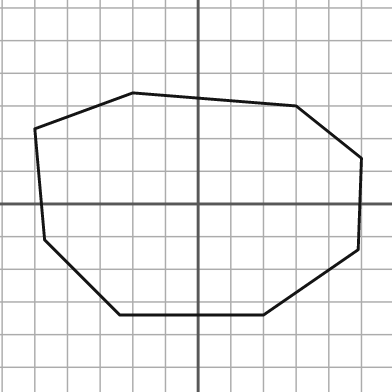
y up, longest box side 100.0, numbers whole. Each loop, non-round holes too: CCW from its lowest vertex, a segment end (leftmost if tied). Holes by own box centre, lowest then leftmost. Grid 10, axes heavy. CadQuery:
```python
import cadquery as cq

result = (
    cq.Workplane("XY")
    .moveTo(-24.0, -34.0)
    .lineTo(20.0, -34.0)
    .lineTo(49.0, -14.0)
    .lineTo(50.0, 14.0)
    .lineTo(30.0, 30.0)
    .lineTo(-20.0, 34.0)
    .lineTo(-50.0, 23.0)
    .lineTo(-47.0, -11.0)
    .close()
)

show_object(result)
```